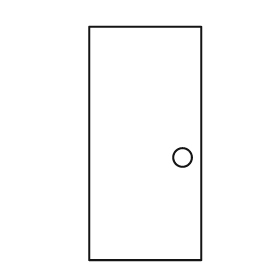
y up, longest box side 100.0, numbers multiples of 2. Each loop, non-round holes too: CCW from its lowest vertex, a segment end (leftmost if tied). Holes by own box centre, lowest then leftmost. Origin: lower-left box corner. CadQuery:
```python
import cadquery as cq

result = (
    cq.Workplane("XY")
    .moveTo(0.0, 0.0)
    .lineTo(48.0, 0.0)
    .lineTo(48.0, 100.0)
    .lineTo(0.0, 100.0)
    .close()
    .moveTo(40.0, 44.0)
    .circle(4.0)
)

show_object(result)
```